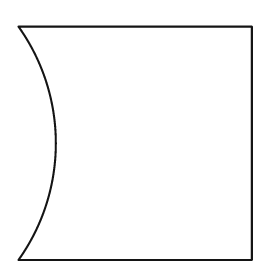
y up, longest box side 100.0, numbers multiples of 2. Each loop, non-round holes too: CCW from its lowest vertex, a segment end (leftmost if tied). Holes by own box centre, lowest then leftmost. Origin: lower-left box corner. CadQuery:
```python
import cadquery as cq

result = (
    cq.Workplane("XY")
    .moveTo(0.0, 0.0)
    .lineTo(100.0, 0.0)
    .lineTo(100.0, 100.0)
    .lineTo(0.0, 100.0)
    .threePointArc((16.0, 50.0), (0.0, 0.0))
    .close()
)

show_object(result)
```